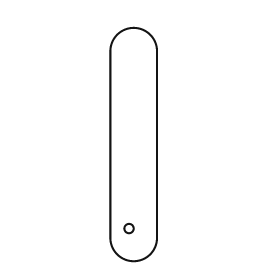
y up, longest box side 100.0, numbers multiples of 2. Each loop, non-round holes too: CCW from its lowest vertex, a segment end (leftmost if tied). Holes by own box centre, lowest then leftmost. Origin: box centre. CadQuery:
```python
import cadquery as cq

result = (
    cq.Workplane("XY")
    .moveTo(-10.0, -40.0)
    .threePointArc((0.0, -50.0), (10.0, -40.0))
    .lineTo(10.0, 40.0)
    .threePointArc((0.0, 50.0), (-10.0, 40.0))
    .close()
    .moveTo(-2.0, -36.0)
    .circle(2.0)
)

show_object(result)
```